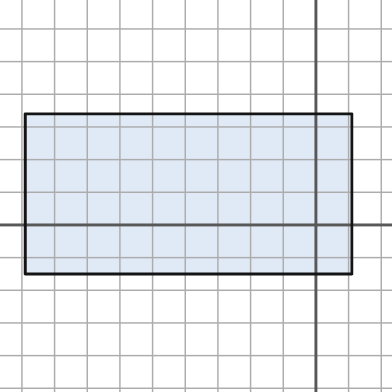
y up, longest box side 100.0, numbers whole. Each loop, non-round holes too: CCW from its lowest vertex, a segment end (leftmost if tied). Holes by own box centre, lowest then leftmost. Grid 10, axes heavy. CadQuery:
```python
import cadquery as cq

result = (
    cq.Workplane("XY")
    .moveTo(-89.0, -15.0)
    .lineTo(11.0, -15.0)
    .lineTo(11.0, 34.0)
    .lineTo(-89.0, 34.0)
    .close()
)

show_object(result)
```